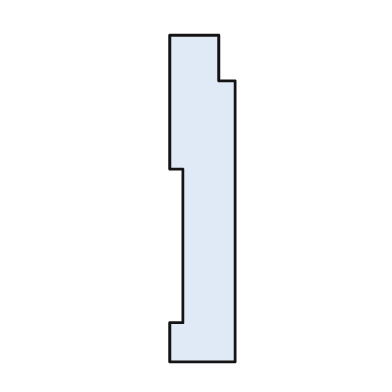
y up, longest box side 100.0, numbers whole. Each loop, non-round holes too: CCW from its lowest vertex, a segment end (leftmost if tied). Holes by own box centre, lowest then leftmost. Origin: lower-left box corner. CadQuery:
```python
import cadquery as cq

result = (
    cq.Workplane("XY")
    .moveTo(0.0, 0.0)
    .lineTo(20.0, 0.0)
    .lineTo(20.0, 86.0)
    .lineTo(15.0, 86.0)
    .lineTo(15.0, 100.0)
    .lineTo(0.0, 100.0)
    .lineTo(0.0, 59.0)
    .lineTo(4.0, 59.0)
    .lineTo(4.0, 12.0)
    .lineTo(0.0, 12.0)
    .close()
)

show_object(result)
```